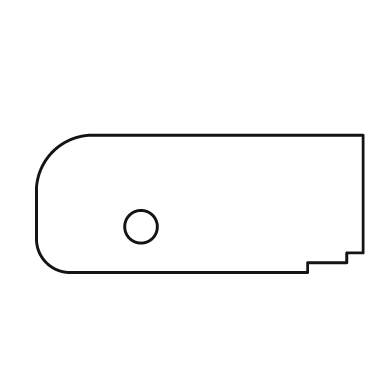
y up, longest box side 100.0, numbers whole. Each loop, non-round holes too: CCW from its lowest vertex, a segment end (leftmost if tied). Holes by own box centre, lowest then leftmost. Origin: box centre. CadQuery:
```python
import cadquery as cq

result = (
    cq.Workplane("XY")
    .moveTo(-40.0, -21.0)
    .lineTo(33.0, -21.0)
    .lineTo(33.0, -18.0)
    .lineTo(45.0, -18.0)
    .lineTo(45.0, -15.0)
    .lineTo(50.0, -15.0)
    .lineTo(50.0, 21.0)
    .lineTo(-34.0, 21.0)
    .threePointArc((-45.0, 16.0), (-50.0, 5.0))
    .lineTo(-50.0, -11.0)
    .threePointArc((-47.0, -18.0), (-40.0, -21.0))
    .close()
    .moveTo(-18.0, -7.0)
    .circle(5.0)
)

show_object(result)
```